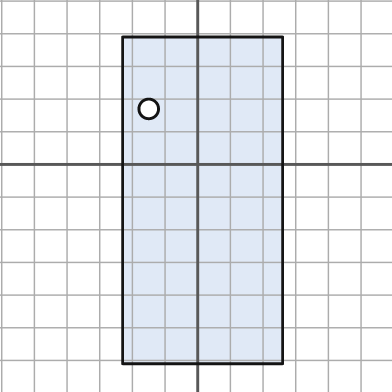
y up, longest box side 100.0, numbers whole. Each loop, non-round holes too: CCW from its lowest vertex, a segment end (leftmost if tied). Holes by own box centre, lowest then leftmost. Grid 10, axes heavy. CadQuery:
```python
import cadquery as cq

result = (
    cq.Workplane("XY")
    .moveTo(-23.0, -61.0)
    .lineTo(26.0, -61.0)
    .lineTo(26.0, 39.0)
    .lineTo(-23.0, 39.0)
    .close()
    .moveTo(-15.0, 17.0)
    .circle(3.0)
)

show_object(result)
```